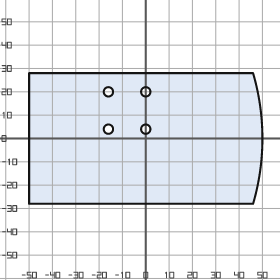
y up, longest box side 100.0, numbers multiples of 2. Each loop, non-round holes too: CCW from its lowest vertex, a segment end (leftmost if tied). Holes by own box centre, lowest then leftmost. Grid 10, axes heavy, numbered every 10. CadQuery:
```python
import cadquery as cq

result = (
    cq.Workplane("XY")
    .moveTo(-50.0, -28.0)
    .lineTo(46.0, -28.0)
    .threePointArc((50.0, 0.0), (46.0, 28.0))
    .lineTo(-50.0, 28.0)
    .close()
    .moveTo(-16.0, 4.0)
    .circle(2.0)
    .moveTo(0.0, 4.0)
    .circle(2.0)
    .moveTo(-16.0, 20.0)
    .circle(2.0)
    .moveTo(0.0, 20.0)
    .circle(2.0)
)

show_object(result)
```